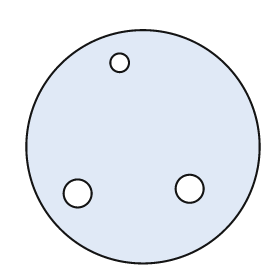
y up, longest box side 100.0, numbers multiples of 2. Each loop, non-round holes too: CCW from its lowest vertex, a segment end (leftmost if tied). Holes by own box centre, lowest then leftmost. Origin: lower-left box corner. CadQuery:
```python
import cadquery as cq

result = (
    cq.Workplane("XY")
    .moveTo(50.0, 50.0)
    .circle(50.0)
    .moveTo(22.0, 30.0)
    .circle(6.0)
    .moveTo(70.0, 32.0)
    .circle(6.0)
    .moveTo(40.0, 86.0)
    .circle(4.0)
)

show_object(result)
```